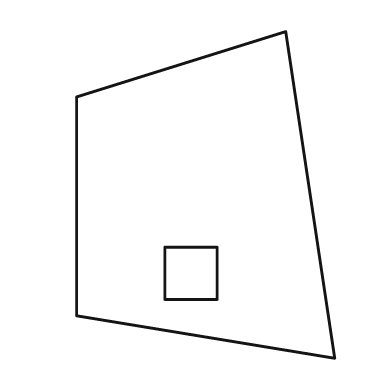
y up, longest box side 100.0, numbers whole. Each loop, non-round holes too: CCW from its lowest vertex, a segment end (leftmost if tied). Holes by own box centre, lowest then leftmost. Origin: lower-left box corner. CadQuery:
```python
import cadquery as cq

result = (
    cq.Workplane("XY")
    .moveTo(79.0, 0.0)
    .lineTo(64.0, 100.0)
    .lineTo(0.0, 80.0)
    .lineTo(0.0, 13.0)
    .close()
    .moveTo(27.0, 18.0)
    .lineTo(43.0, 18.0)
    .lineTo(43.0, 34.0)
    .lineTo(27.0, 34.0)
    .close()
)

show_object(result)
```